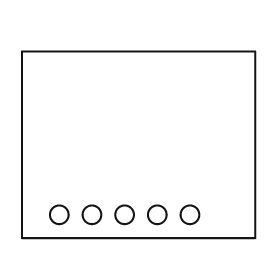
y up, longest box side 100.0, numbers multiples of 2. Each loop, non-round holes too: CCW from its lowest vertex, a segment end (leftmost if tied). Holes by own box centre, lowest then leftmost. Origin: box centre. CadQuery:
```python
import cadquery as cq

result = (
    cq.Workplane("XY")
    .moveTo(-50.0, -40.0)
    .lineTo(50.0, -40.0)
    .lineTo(50.0, 40.0)
    .lineTo(-50.0, 40.0)
    .close()
    .moveTo(-34.0, -30.0)
    .circle(4.0)
    .moveTo(-20.0, -30.0)
    .circle(4.0)
    .moveTo(-6.0, -30.0)
    .circle(4.0)
    .moveTo(8.0, -30.0)
    .circle(4.0)
    .moveTo(22.0, -30.0)
    .circle(4.0)
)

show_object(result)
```